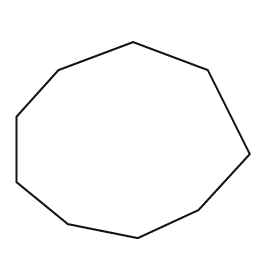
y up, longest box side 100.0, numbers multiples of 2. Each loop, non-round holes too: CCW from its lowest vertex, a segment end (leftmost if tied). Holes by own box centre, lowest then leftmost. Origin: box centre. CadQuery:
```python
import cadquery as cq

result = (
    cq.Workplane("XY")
    .moveTo(2.0, -42.0)
    .lineTo(28.0, -30.0)
    .lineTo(50.0, -6.0)
    .lineTo(32.0, 30.0)
    .lineTo(0.0, 42.0)
    .lineTo(-32.0, 30.0)
    .lineTo(-50.0, 10.0)
    .lineTo(-50.0, -18.0)
    .lineTo(-28.0, -36.0)
    .close()
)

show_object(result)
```